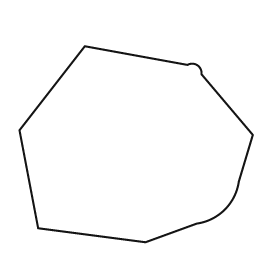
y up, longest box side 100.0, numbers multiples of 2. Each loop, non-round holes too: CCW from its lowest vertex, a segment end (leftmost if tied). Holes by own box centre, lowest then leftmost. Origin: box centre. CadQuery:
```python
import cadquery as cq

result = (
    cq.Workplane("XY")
    .moveTo(4.0, -42.0)
    .lineTo(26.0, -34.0)
    .threePointArc((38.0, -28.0), (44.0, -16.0))
    .lineTo(50.0, 4.0)
    .lineTo(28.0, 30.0)
    .threePointArc((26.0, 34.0), (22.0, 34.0))
    .lineTo(-22.0, 42.0)
    .lineTo(-50.0, 6.0)
    .lineTo(-42.0, -36.0)
    .close()
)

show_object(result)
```